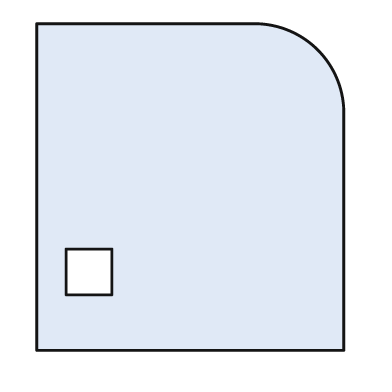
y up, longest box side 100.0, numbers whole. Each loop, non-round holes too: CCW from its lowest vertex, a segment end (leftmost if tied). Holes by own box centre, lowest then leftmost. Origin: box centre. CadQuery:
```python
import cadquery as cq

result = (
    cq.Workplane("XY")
    .moveTo(-47.0, -50.0)
    .lineTo(47.0, -50.0)
    .lineTo(47.0, 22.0)
    .threePointArc((39.0, 42.0), (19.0, 50.0))
    .lineTo(-47.0, 50.0)
    .close()
    .moveTo(-38.0, -33.0)
    .lineTo(-24.0, -33.0)
    .lineTo(-24.0, -19.0)
    .lineTo(-38.0, -19.0)
    .close()
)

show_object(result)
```